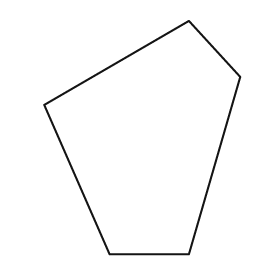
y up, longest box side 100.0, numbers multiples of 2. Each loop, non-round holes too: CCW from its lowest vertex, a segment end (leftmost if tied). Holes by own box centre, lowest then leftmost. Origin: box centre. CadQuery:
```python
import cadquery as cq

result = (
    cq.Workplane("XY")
    .moveTo(-14.0, -50.0)
    .lineTo(20.0, -50.0)
    .lineTo(42.0, 26.0)
    .lineTo(20.0, 50.0)
    .lineTo(-42.0, 14.0)
    .close()
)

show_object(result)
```